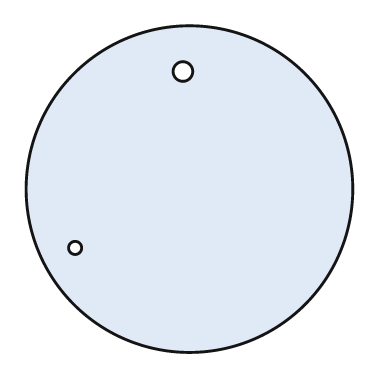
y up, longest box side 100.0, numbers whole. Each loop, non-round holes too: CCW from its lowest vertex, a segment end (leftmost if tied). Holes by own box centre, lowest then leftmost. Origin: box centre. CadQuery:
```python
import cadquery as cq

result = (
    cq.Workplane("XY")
    .moveTo(0.0, 0.0)
    .circle(50.0)
    .moveTo(-35.0, -18.0)
    .circle(2.0)
    .moveTo(-2.0, 36.0)
    .circle(3.0)
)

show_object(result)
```